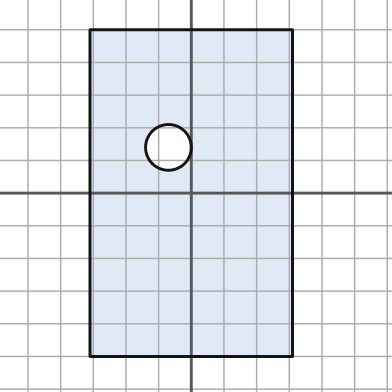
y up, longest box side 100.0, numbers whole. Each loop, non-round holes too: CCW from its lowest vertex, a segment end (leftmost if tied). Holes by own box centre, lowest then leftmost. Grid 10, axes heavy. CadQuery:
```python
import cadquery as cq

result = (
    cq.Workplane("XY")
    .moveTo(-31.0, -50.0)
    .lineTo(31.0, -50.0)
    .lineTo(31.0, 50.0)
    .lineTo(-31.0, 50.0)
    .close()
    .moveTo(-7.0, 14.0)
    .circle(7.0)
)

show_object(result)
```